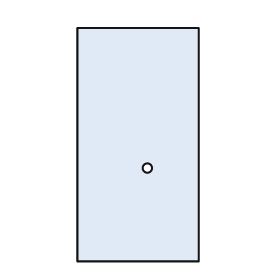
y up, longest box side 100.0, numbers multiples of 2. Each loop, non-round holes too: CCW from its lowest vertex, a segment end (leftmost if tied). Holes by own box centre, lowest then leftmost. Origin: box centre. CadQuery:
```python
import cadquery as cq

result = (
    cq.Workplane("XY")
    .moveTo(-26.0, -50.0)
    .lineTo(26.0, -50.0)
    .lineTo(26.0, 50.0)
    .lineTo(-26.0, 50.0)
    .close()
    .moveTo(4.0, -10.0)
    .circle(2.0)
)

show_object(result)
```